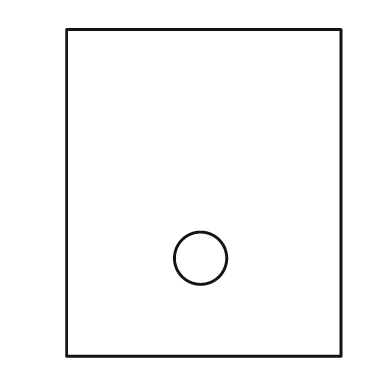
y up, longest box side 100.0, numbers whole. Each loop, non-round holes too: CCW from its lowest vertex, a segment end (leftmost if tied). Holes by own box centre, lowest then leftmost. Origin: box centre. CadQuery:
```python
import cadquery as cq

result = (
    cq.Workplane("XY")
    .moveTo(-42.0, -50.0)
    .lineTo(42.0, -50.0)
    .lineTo(42.0, 50.0)
    .lineTo(-42.0, 50.0)
    .close()
    .moveTo(-1.0, -20.0)
    .circle(8.0)
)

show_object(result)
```